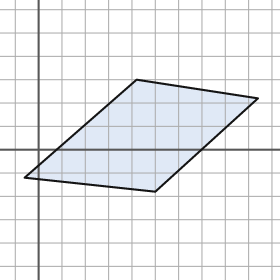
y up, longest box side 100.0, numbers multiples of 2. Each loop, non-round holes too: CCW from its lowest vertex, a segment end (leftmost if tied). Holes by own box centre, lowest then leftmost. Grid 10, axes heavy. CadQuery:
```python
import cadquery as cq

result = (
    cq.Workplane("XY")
    .moveTo(50.0, -18.0)
    .lineTo(94.0, 22.0)
    .lineTo(42.0, 30.0)
    .lineTo(-6.0, -12.0)
    .close()
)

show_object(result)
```